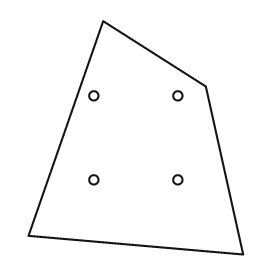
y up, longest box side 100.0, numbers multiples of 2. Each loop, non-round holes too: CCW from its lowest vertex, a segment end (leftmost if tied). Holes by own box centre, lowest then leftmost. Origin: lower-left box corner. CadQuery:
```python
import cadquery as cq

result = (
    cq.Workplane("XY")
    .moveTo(92.0, 0.0)
    .lineTo(76.0, 72.0)
    .lineTo(32.0, 100.0)
    .lineTo(0.0, 8.0)
    .close()
    .moveTo(28.0, 32.0)
    .circle(2.0)
    .moveTo(64.0, 32.0)
    .circle(2.0)
    .moveTo(28.0, 68.0)
    .circle(2.0)
    .moveTo(64.0, 68.0)
    .circle(2.0)
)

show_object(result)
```